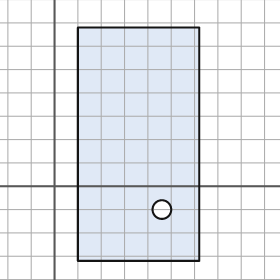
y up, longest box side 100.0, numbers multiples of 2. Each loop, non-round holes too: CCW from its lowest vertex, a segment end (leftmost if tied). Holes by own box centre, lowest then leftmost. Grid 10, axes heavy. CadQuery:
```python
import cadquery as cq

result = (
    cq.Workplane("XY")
    .moveTo(10.0, -32.0)
    .lineTo(62.0, -32.0)
    .lineTo(62.0, 68.0)
    .lineTo(10.0, 68.0)
    .close()
    .moveTo(46.0, -10.0)
    .circle(4.0)
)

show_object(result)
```